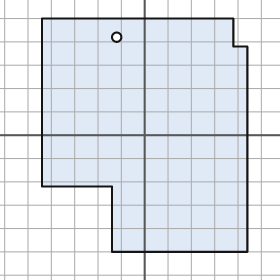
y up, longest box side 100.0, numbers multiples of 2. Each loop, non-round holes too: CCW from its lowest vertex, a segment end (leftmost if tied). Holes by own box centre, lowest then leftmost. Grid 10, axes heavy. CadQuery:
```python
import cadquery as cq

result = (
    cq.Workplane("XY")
    .moveTo(-14.0, -50.0)
    .lineTo(44.0, -50.0)
    .lineTo(44.0, 38.0)
    .lineTo(38.0, 38.0)
    .lineTo(38.0, 50.0)
    .lineTo(-44.0, 50.0)
    .lineTo(-44.0, -22.0)
    .lineTo(-14.0, -22.0)
    .close()
    .moveTo(-12.0, 42.0)
    .circle(2.0)
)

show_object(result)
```